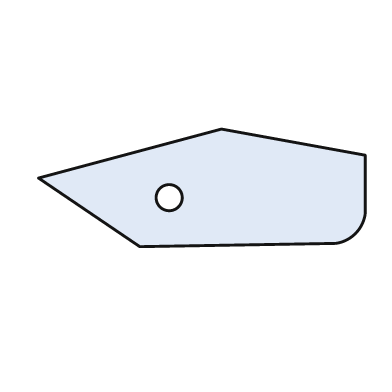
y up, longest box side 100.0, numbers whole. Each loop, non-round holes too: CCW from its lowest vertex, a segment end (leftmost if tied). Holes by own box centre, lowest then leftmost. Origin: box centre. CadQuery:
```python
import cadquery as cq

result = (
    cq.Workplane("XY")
    .moveTo(-19.0, -18.0)
    .lineTo(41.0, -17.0)
    .threePointArc((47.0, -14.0), (50.0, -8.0))
    .lineTo(50.0, 10.0)
    .lineTo(6.0, 18.0)
    .lineTo(-50.0, 3.0)
    .close()
    .moveTo(-10.0, -3.0)
    .circle(4.0)
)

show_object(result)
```